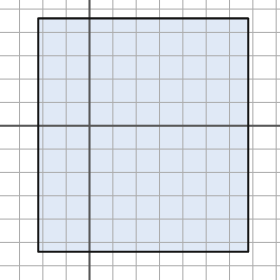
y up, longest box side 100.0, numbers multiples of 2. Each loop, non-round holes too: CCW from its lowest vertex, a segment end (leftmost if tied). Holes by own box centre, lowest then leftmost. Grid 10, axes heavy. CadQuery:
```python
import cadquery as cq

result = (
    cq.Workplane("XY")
    .moveTo(-22.0, -54.0)
    .lineTo(68.0, -54.0)
    .lineTo(68.0, 46.0)
    .lineTo(-22.0, 46.0)
    .close()
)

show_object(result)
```